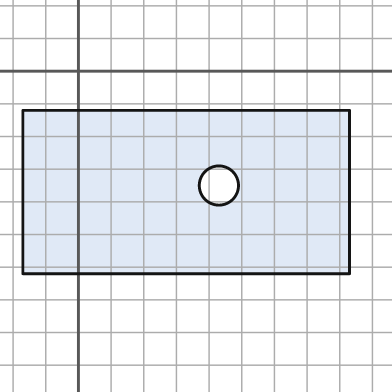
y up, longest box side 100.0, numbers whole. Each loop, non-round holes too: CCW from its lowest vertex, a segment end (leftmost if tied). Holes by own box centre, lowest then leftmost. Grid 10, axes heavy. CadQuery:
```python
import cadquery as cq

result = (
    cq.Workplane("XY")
    .moveTo(-17.0, -62.0)
    .lineTo(83.0, -62.0)
    .lineTo(83.0, -12.0)
    .lineTo(-17.0, -12.0)
    .close()
    .moveTo(43.0, -35.0)
    .circle(6.0)
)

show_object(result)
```